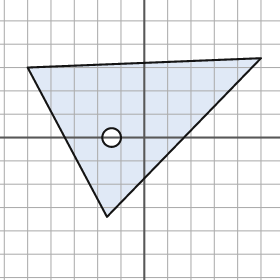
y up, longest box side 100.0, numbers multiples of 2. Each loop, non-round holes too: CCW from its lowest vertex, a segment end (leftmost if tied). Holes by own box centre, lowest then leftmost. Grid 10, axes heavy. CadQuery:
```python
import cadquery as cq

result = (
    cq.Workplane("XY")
    .moveTo(-16.0, -34.0)
    .lineTo(50.0, 34.0)
    .lineTo(-50.0, 30.0)
    .close()
    .moveTo(-14.0, 0.0)
    .circle(4.0)
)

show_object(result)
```